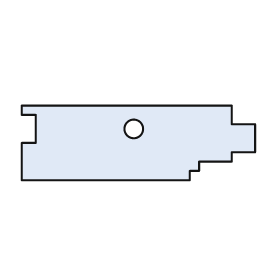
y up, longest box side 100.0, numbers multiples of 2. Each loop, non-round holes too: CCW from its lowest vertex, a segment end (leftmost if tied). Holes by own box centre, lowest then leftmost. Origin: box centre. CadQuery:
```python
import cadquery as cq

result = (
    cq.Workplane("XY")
    .moveTo(-50.0, -16.0)
    .lineTo(22.0, -16.0)
    .lineTo(22.0, -12.0)
    .lineTo(26.0, -12.0)
    .lineTo(26.0, -8.0)
    .lineTo(40.0, -8.0)
    .lineTo(40.0, -4.0)
    .lineTo(50.0, -4.0)
    .lineTo(50.0, 8.0)
    .lineTo(40.0, 8.0)
    .lineTo(40.0, 16.0)
    .lineTo(-50.0, 16.0)
    .lineTo(-50.0, 12.0)
    .lineTo(-44.0, 12.0)
    .lineTo(-44.0, 0.0)
    .lineTo(-50.0, 0.0)
    .close()
    .moveTo(-2.0, 6.0)
    .circle(4.0)
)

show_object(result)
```